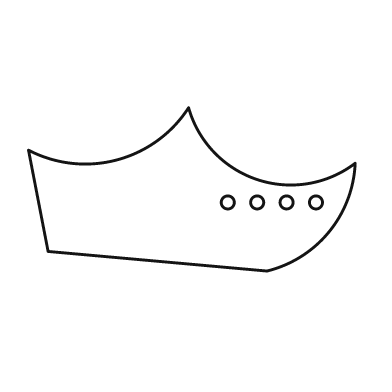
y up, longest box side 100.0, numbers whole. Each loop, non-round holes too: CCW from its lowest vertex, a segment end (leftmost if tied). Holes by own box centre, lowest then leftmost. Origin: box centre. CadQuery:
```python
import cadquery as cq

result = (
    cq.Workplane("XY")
    .moveTo(23.0, -25.0)
    .threePointArc((42.0, -13.0), (50.0, 8.0))
    .threePointArc((20.0, 3.0), (-1.0, 25.0))
    .threePointArc((-23.0, 9.0), (-50.0, 12.0))
    .lineTo(-44.0, -19.0)
    .close()
    .moveTo(11.0, -4.0)
    .circle(2.0)
    .moveTo(20.0, -4.0)
    .circle(2.0)
    .moveTo(29.0, -4.0)
    .circle(2.0)
    .moveTo(38.0, -4.0)
    .circle(2.0)
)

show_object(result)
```